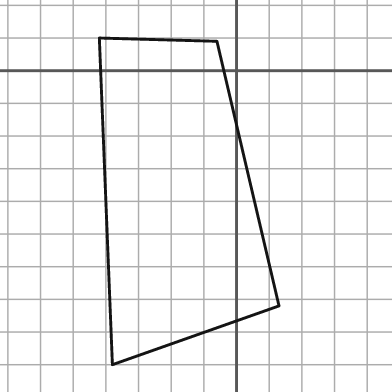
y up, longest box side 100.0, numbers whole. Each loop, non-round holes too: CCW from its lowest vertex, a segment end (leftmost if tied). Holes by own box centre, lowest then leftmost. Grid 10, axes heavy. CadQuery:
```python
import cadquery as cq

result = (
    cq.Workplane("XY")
    .moveTo(-38.0, -90.0)
    .lineTo(13.0, -72.0)
    .lineTo(-6.0, 9.0)
    .lineTo(-42.0, 10.0)
    .close()
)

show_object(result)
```